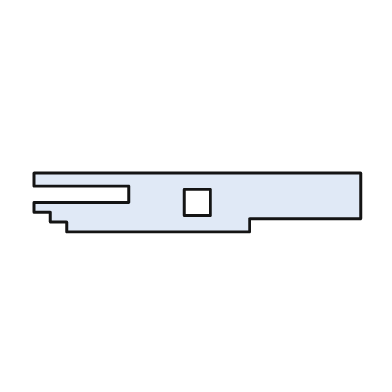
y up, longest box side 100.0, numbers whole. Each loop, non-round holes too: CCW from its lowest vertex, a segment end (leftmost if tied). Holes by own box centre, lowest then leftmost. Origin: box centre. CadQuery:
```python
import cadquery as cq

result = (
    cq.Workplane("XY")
    .moveTo(-40.0, -9.0)
    .lineTo(16.0, -9.0)
    .lineTo(16.0, -5.0)
    .lineTo(50.0, -5.0)
    .lineTo(50.0, 9.0)
    .lineTo(-50.0, 9.0)
    .lineTo(-50.0, 5.0)
    .lineTo(-21.0, 5.0)
    .lineTo(-21.0, 0.0)
    .lineTo(-50.0, 0.0)
    .lineTo(-50.0, -3.0)
    .lineTo(-45.0, -3.0)
    .lineTo(-45.0, -6.0)
    .lineTo(-40.0, -6.0)
    .close()
    .moveTo(-4.0, -4.0)
    .lineTo(4.0, -4.0)
    .lineTo(4.0, 4.0)
    .lineTo(-4.0, 4.0)
    .close()
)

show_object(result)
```